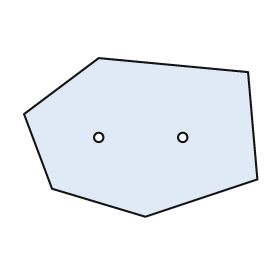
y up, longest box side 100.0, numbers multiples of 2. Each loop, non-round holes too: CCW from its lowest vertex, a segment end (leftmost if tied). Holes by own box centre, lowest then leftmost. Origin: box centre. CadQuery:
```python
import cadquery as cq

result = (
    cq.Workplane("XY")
    .moveTo(2.0, -34.0)
    .lineTo(50.0, -18.0)
    .lineTo(46.0, 28.0)
    .lineTo(-18.0, 34.0)
    .lineTo(-50.0, 10.0)
    .lineTo(-38.0, -22.0)
    .close()
    .moveTo(-18.0, 0.0)
    .circle(2.0)
    .moveTo(18.0, 0.0)
    .circle(2.0)
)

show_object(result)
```